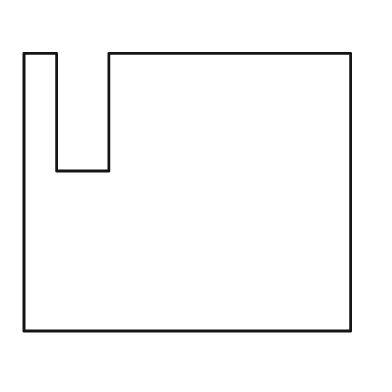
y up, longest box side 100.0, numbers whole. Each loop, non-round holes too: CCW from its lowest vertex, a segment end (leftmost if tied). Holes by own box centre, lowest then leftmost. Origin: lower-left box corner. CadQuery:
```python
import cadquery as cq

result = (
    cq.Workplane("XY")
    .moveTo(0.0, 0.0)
    .lineTo(100.0, 0.0)
    .lineTo(100.0, 85.0)
    .lineTo(26.0, 85.0)
    .lineTo(26.0, 49.0)
    .lineTo(10.0, 49.0)
    .lineTo(10.0, 85.0)
    .lineTo(0.0, 85.0)
    .close()
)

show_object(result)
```